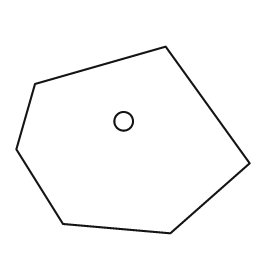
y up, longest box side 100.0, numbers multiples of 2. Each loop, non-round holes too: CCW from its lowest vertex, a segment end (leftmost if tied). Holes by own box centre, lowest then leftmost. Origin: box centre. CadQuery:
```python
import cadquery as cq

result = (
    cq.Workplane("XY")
    .moveTo(16.0, -40.0)
    .lineTo(50.0, -10.0)
    .lineTo(14.0, 40.0)
    .lineTo(-42.0, 24.0)
    .lineTo(-50.0, -4.0)
    .lineTo(-30.0, -36.0)
    .close()
    .moveTo(-4.0, 8.0)
    .circle(4.0)
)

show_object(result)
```